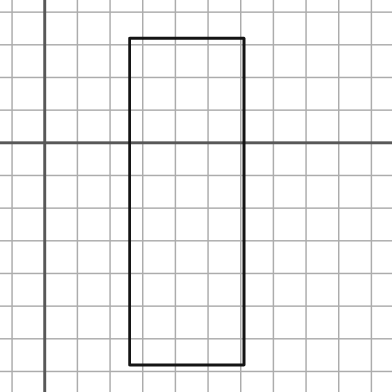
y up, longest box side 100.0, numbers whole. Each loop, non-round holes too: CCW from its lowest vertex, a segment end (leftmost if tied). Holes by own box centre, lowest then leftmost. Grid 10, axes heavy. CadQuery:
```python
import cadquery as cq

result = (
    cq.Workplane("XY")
    .moveTo(26.0, -68.0)
    .lineTo(61.0, -68.0)
    .lineTo(61.0, 32.0)
    .lineTo(26.0, 32.0)
    .close()
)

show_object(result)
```